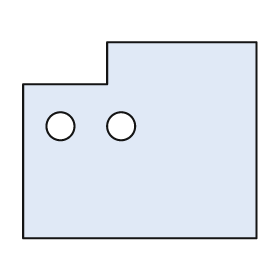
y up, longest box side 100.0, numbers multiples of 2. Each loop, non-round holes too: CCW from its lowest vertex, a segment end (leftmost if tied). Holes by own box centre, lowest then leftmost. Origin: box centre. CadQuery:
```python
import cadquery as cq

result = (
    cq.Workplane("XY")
    .moveTo(-50.0, -42.0)
    .lineTo(50.0, -42.0)
    .lineTo(50.0, 42.0)
    .lineTo(-14.0, 42.0)
    .lineTo(-14.0, 24.0)
    .lineTo(-50.0, 24.0)
    .close()
    .moveTo(-34.0, 6.0)
    .circle(6.0)
    .moveTo(-8.0, 6.0)
    .circle(6.0)
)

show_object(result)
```